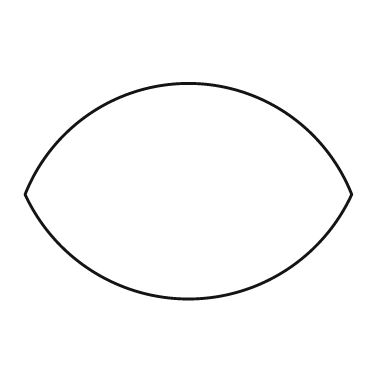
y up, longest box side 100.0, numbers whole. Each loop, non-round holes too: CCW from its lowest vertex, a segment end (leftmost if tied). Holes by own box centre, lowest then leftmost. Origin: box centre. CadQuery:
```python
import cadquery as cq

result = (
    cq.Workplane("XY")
    .moveTo(-50.0, -1.0)
    .threePointArc((0.0, -33.0), (50.0, -1.0))
    .threePointArc((0.0, 33.0), (-50.0, -1.0))
    .close()
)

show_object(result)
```